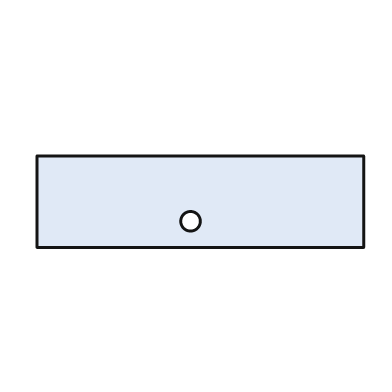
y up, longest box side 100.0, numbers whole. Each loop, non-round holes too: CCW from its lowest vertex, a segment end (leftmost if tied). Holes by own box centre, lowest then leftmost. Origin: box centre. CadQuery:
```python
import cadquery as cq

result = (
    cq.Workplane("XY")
    .moveTo(-50.0, -14.0)
    .lineTo(50.0, -14.0)
    .lineTo(50.0, 14.0)
    .lineTo(-50.0, 14.0)
    .close()
    .moveTo(-3.0, -6.0)
    .circle(3.0)
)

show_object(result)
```